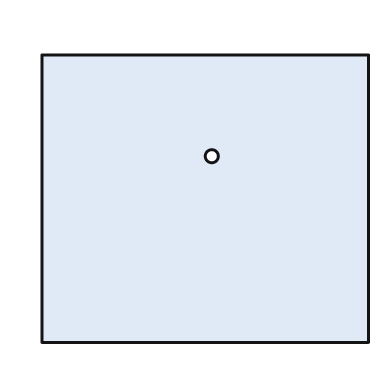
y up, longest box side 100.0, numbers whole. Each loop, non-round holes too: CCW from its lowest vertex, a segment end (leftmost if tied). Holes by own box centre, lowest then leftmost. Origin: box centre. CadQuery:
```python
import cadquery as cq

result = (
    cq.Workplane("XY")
    .moveTo(-50.0, -44.0)
    .lineTo(50.0, -44.0)
    .lineTo(50.0, 44.0)
    .lineTo(-50.0, 44.0)
    .close()
    .moveTo(2.0, 13.0)
    .circle(2.0)
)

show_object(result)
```